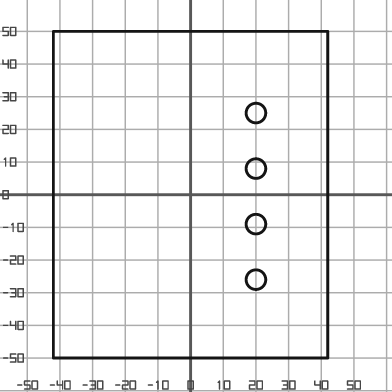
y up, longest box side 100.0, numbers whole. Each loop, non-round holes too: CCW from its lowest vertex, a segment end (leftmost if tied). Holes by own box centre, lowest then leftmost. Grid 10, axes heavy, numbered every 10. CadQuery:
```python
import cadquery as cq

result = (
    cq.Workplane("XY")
    .moveTo(-42.0, -50.0)
    .lineTo(42.0, -50.0)
    .lineTo(42.0, 50.0)
    .lineTo(-42.0, 50.0)
    .close()
    .moveTo(20.0, -26.0)
    .circle(3.0)
    .moveTo(20.0, -9.0)
    .circle(3.0)
    .moveTo(20.0, 8.0)
    .circle(3.0)
    .moveTo(20.0, 25.0)
    .circle(3.0)
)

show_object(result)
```